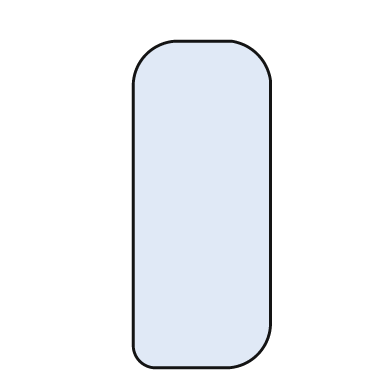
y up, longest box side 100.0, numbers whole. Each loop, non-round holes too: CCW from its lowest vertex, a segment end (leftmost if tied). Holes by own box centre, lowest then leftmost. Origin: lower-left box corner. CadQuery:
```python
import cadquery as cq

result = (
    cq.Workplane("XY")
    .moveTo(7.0, 0.0)
    .lineTo(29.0, 0.0)
    .threePointArc((38.0, 4.0), (42.0, 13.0))
    .lineTo(42.0, 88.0)
    .threePointArc((38.0, 96.0), (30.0, 100.0))
    .lineTo(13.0, 100.0)
    .threePointArc((4.0, 96.0), (0.0, 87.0))
    .lineTo(0.0, 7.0)
    .threePointArc((2.0, 2.0), (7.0, 0.0))
    .close()
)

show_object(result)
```